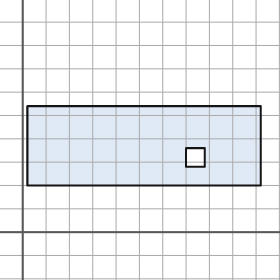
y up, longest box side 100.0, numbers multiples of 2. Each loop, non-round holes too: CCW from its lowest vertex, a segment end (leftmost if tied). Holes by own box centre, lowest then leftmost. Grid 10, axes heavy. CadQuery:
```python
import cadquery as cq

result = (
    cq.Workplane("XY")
    .moveTo(2.0, 20.0)
    .lineTo(102.0, 20.0)
    .lineTo(102.0, 54.0)
    .lineTo(2.0, 54.0)
    .close()
    .moveTo(70.0, 28.0)
    .lineTo(78.0, 28.0)
    .lineTo(78.0, 36.0)
    .lineTo(70.0, 36.0)
    .close()
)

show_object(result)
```